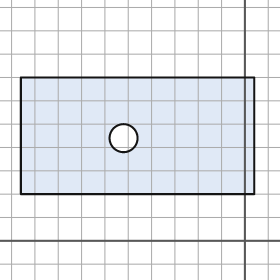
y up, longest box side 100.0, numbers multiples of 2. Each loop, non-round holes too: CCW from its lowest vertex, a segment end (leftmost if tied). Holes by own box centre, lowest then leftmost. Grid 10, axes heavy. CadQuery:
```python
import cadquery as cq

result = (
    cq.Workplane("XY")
    .moveTo(-96.0, 20.0)
    .lineTo(4.0, 20.0)
    .lineTo(4.0, 70.0)
    .lineTo(-96.0, 70.0)
    .close()
    .moveTo(-52.0, 44.0)
    .circle(6.0)
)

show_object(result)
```